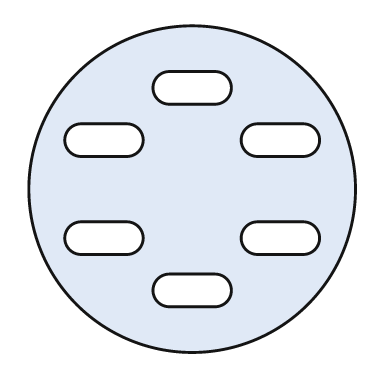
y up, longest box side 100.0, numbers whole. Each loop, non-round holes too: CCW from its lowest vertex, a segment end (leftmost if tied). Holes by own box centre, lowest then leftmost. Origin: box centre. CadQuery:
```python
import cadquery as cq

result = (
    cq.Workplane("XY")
    .moveTo(0.0, 0.0)
    .circle(50.0)
    .moveTo(-7.0, -36.0)
    .lineTo(7.0, -36.0)
    .threePointArc((12.0, -31.0), (7.0, -26.0))
    .lineTo(-7.0, -26.0)
    .threePointArc((-12.0, -31.0), (-7.0, -36.0))
    .close()
    .moveTo(-34.0, -20.0)
    .lineTo(-20.0, -20.0)
    .threePointArc((-15.0, -15.0), (-20.0, -10.0))
    .lineTo(-34.0, -10.0)
    .threePointArc((-39.0, -15.0), (-34.0, -20.0))
    .close()
    .moveTo(20.0, -20.0)
    .lineTo(34.0, -20.0)
    .threePointArc((39.0, -15.0), (34.0, -10.0))
    .lineTo(20.0, -10.0)
    .threePointArc((15.0, -15.0), (20.0, -20.0))
    .close()
    .moveTo(-34.0, 10.0)
    .lineTo(-20.0, 10.0)
    .threePointArc((-15.0, 15.0), (-20.0, 20.0))
    .lineTo(-34.0, 20.0)
    .threePointArc((-39.0, 15.0), (-34.0, 10.0))
    .close()
    .moveTo(20.0, 10.0)
    .lineTo(34.0, 10.0)
    .threePointArc((39.0, 15.0), (34.0, 20.0))
    .lineTo(20.0, 20.0)
    .threePointArc((15.0, 15.0), (20.0, 10.0))
    .close()
    .moveTo(-7.0, 26.0)
    .lineTo(7.0, 26.0)
    .threePointArc((12.0, 31.0), (7.0, 36.0))
    .lineTo(-7.0, 36.0)
    .threePointArc((-12.0, 31.0), (-7.0, 26.0))
    .close()
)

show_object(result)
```